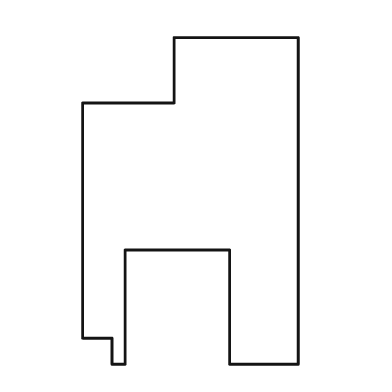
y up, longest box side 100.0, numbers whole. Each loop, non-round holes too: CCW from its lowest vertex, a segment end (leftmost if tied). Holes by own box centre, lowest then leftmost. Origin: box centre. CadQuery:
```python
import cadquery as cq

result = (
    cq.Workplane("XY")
    .moveTo(-24.0, -50.0)
    .lineTo(-20.0, -50.0)
    .lineTo(-20.0, -15.0)
    .lineTo(12.0, -15.0)
    .lineTo(12.0, -50.0)
    .lineTo(33.0, -50.0)
    .lineTo(33.0, 50.0)
    .lineTo(-5.0, 50.0)
    .lineTo(-5.0, 30.0)
    .lineTo(-33.0, 30.0)
    .lineTo(-33.0, -42.0)
    .lineTo(-24.0, -42.0)
    .close()
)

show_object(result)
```